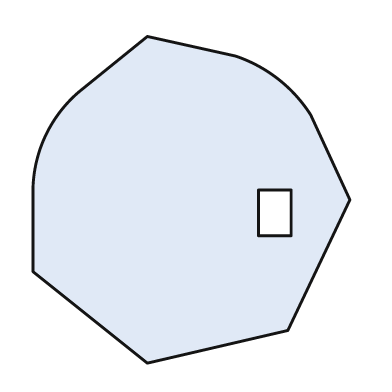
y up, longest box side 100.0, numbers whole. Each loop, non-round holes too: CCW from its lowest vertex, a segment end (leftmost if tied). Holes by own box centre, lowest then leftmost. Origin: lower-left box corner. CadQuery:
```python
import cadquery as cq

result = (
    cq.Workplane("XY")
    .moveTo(35.0, 0.0)
    .lineTo(78.0, 10.0)
    .lineTo(97.0, 50.0)
    .lineTo(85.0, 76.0)
    .threePointArc((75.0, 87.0), (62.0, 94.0))
    .lineTo(35.0, 100.0)
    .lineTo(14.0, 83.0)
    .threePointArc((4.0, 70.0), (0.0, 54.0))
    .lineTo(0.0, 28.0)
    .close()
    .moveTo(69.0, 39.0)
    .lineTo(79.0, 39.0)
    .lineTo(79.0, 53.0)
    .lineTo(69.0, 53.0)
    .close()
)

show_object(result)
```